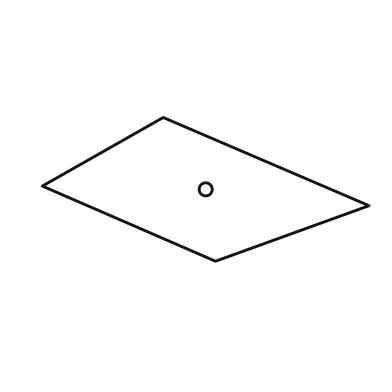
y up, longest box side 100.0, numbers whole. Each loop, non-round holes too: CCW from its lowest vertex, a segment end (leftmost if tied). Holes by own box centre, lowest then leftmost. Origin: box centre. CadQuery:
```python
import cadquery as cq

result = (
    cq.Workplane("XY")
    .moveTo(3.0, -22.0)
    .lineTo(50.0, -5.0)
    .lineTo(-13.0, 22.0)
    .lineTo(-50.0, 1.0)
    .close()
    .moveTo(0.0, 0.0)
    .circle(2.0)
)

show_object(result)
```